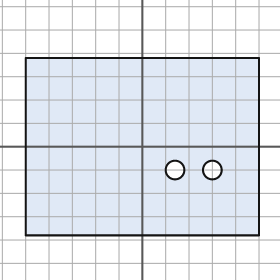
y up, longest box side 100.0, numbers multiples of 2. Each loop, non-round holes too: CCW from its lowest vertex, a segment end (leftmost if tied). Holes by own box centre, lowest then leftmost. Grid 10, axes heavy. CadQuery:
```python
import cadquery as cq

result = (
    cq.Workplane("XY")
    .moveTo(-50.0, -38.0)
    .lineTo(50.0, -38.0)
    .lineTo(50.0, 38.0)
    .lineTo(-50.0, 38.0)
    .close()
    .moveTo(14.0, -10.0)
    .circle(4.0)
    .moveTo(30.0, -10.0)
    .circle(4.0)
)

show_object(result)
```